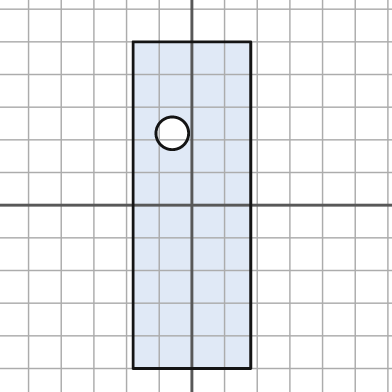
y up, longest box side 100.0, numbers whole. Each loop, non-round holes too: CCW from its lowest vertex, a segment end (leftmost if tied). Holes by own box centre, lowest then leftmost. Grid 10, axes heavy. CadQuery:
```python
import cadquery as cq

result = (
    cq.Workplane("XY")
    .moveTo(-18.0, -50.0)
    .lineTo(18.0, -50.0)
    .lineTo(18.0, 50.0)
    .lineTo(-18.0, 50.0)
    .close()
    .moveTo(-6.0, 22.0)
    .circle(5.0)
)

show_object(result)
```